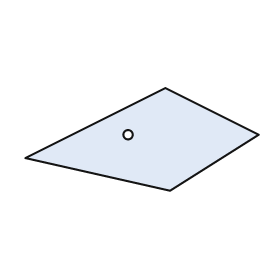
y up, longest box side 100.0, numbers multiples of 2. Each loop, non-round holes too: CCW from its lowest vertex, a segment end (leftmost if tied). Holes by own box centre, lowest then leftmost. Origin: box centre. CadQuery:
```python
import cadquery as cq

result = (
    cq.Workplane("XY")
    .moveTo(12.0, -22.0)
    .lineTo(50.0, 2.0)
    .lineTo(10.0, 22.0)
    .lineTo(-50.0, -8.0)
    .close()
    .moveTo(-6.0, 2.0)
    .circle(2.0)
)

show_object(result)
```